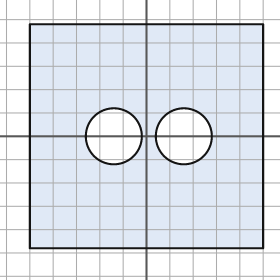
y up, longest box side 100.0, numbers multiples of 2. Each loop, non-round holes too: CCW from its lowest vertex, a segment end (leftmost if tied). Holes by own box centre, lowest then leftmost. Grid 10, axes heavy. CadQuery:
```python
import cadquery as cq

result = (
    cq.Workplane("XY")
    .moveTo(-50.0, -48.0)
    .lineTo(50.0, -48.0)
    .lineTo(50.0, 48.0)
    .lineTo(-50.0, 48.0)
    .close()
    .moveTo(-14.0, 0.0)
    .circle(12.0)
    .moveTo(16.0, 0.0)
    .circle(12.0)
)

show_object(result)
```